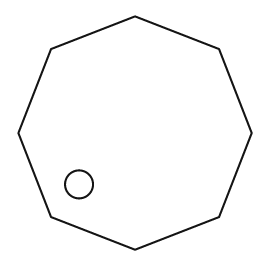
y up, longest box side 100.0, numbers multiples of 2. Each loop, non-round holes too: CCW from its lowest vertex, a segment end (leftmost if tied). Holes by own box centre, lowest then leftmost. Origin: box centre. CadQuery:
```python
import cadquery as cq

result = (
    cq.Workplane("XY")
    .moveTo(0.0, -50.0)
    .lineTo(36.0, -36.0)
    .lineTo(50.0, 0.0)
    .lineTo(36.0, 36.0)
    .lineTo(0.0, 50.0)
    .lineTo(-36.0, 36.0)
    .lineTo(-50.0, 0.0)
    .lineTo(-36.0, -36.0)
    .close()
    .moveTo(-24.0, -22.0)
    .circle(6.0)
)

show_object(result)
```